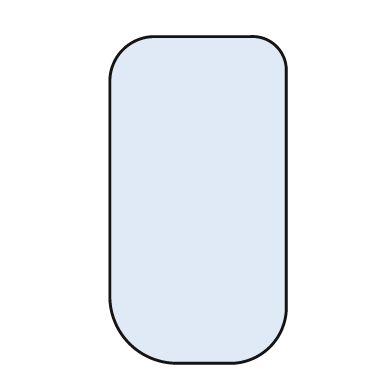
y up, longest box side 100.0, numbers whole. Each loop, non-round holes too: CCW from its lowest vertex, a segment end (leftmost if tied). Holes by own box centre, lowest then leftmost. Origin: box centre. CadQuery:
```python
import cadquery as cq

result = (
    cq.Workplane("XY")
    .moveTo(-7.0, -50.0)
    .lineTo(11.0, -50.0)
    .threePointArc((22.0, -45.0), (27.0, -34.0))
    .lineTo(27.0, 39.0)
    .threePointArc((24.0, 47.0), (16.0, 50.0))
    .lineTo(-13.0, 50.0)
    .threePointArc((-23.0, 46.0), (-27.0, 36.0))
    .lineTo(-27.0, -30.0)
    .threePointArc((-21.0, -44.0), (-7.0, -50.0))
    .close()
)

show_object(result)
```